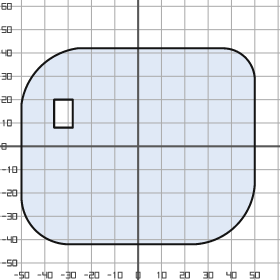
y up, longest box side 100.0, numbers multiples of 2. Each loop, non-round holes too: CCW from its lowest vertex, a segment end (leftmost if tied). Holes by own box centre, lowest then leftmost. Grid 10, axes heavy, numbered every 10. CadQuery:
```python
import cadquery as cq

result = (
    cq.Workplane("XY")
    .moveTo(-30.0, -42.0)
    .lineTo(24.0, -42.0)
    .threePointArc((42.0, -34.0), (50.0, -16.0))
    .lineTo(50.0, 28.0)
    .threePointArc((46.0, 38.0), (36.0, 42.0))
    .lineTo(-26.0, 42.0)
    .threePointArc((-42.0, 34.0), (-50.0, 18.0))
    .lineTo(-50.0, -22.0)
    .threePointArc((-44.0, -36.0), (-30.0, -42.0))
    .close()
    .moveTo(-36.0, 8.0)
    .lineTo(-28.0, 8.0)
    .lineTo(-28.0, 20.0)
    .lineTo(-36.0, 20.0)
    .close()
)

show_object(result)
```